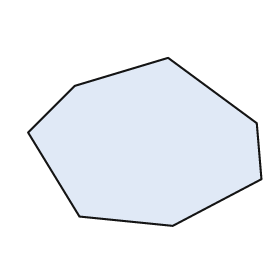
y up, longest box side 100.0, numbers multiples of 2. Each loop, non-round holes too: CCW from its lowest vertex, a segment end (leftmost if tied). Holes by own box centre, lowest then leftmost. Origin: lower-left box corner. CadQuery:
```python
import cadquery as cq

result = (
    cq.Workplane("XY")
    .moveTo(62.0, 0.0)
    .lineTo(100.0, 20.0)
    .lineTo(98.0, 44.0)
    .lineTo(60.0, 72.0)
    .lineTo(20.0, 60.0)
    .lineTo(0.0, 40.0)
    .lineTo(22.0, 4.0)
    .close()
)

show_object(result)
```